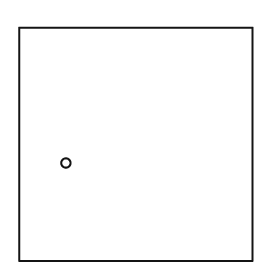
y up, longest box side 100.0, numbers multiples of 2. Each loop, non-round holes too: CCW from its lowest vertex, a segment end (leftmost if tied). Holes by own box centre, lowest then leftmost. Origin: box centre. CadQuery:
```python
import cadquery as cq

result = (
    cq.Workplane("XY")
    .moveTo(-50.0, -50.0)
    .lineTo(50.0, -50.0)
    .lineTo(50.0, 50.0)
    .lineTo(-50.0, 50.0)
    .close()
    .moveTo(-30.0, -8.0)
    .circle(2.0)
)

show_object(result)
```